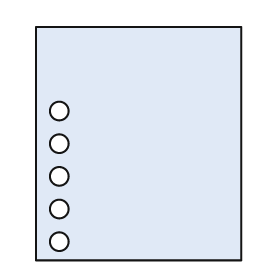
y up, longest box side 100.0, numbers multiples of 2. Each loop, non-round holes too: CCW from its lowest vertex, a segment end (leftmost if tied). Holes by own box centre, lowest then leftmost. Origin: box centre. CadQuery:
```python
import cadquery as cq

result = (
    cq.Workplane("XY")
    .moveTo(-44.0, -50.0)
    .lineTo(44.0, -50.0)
    .lineTo(44.0, 50.0)
    .lineTo(-44.0, 50.0)
    .close()
    .moveTo(-34.0, -42.0)
    .circle(4.0)
    .moveTo(-34.0, -28.0)
    .circle(4.0)
    .moveTo(-34.0, -14.0)
    .circle(4.0)
    .moveTo(-34.0, 0.0)
    .circle(4.0)
    .moveTo(-34.0, 14.0)
    .circle(4.0)
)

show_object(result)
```